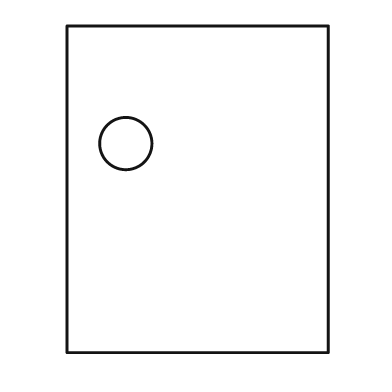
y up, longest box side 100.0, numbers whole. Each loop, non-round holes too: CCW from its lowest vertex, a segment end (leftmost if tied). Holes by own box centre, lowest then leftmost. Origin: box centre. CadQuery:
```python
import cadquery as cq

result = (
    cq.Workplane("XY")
    .moveTo(-40.0, -50.0)
    .lineTo(40.0, -50.0)
    .lineTo(40.0, 50.0)
    .lineTo(-40.0, 50.0)
    .close()
    .moveTo(-22.0, 14.0)
    .circle(8.0)
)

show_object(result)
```